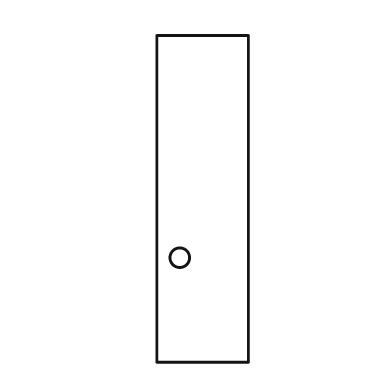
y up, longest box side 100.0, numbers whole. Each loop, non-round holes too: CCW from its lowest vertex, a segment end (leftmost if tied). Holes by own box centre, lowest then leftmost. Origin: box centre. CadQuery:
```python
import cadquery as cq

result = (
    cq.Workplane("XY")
    .moveTo(-14.0, -50.0)
    .lineTo(14.0, -50.0)
    .lineTo(14.0, 50.0)
    .lineTo(-14.0, 50.0)
    .close()
    .moveTo(-7.0, -18.0)
    .circle(3.0)
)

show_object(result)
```